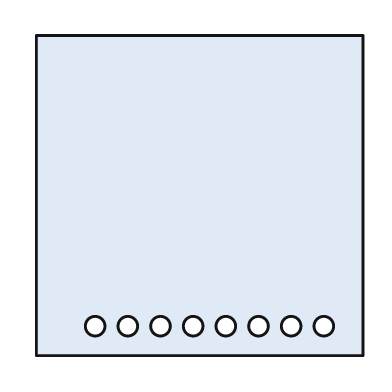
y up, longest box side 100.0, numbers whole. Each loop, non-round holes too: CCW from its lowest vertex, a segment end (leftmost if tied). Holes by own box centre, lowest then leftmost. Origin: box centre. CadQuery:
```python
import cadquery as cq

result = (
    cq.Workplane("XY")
    .moveTo(-50.0, -49.0)
    .lineTo(50.0, -49.0)
    .lineTo(50.0, 49.0)
    .lineTo(-50.0, 49.0)
    .close()
    .moveTo(-32.0, -40.0)
    .circle(3.0)
    .moveTo(-22.0, -40.0)
    .circle(3.0)
    .moveTo(-12.0, -40.0)
    .circle(3.0)
    .moveTo(-2.0, -40.0)
    .circle(3.0)
    .moveTo(8.0, -40.0)
    .circle(3.0)
    .moveTo(18.0, -40.0)
    .circle(3.0)
    .moveTo(28.0, -40.0)
    .circle(3.0)
    .moveTo(38.0, -40.0)
    .circle(3.0)
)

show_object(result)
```